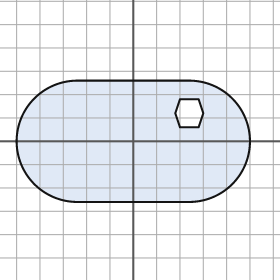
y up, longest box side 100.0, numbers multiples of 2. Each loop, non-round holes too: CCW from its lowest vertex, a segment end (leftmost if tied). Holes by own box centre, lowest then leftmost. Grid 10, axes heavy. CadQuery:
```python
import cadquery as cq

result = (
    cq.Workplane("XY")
    .moveTo(-24.0, -26.0)
    .lineTo(24.0, -26.0)
    .threePointArc((50.0, 0.0), (24.0, 26.0))
    .lineTo(-24.0, 26.0)
    .threePointArc((-50.0, 0.0), (-24.0, -26.0))
    .close()
    .moveTo(20.0, 6.0)
    .lineTo(28.0, 6.0)
    .lineTo(30.0, 12.0)
    .lineTo(28.0, 18.0)
    .lineTo(20.0, 18.0)
    .lineTo(18.0, 12.0)
    .close()
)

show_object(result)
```